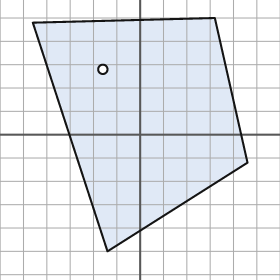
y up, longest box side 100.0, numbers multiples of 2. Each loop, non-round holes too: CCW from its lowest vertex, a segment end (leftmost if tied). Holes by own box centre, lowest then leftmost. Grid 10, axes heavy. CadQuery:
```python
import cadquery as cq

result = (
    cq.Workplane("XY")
    .moveTo(-14.0, -50.0)
    .lineTo(46.0, -12.0)
    .lineTo(32.0, 50.0)
    .lineTo(-46.0, 48.0)
    .close()
    .moveTo(-16.0, 28.0)
    .circle(2.0)
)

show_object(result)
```